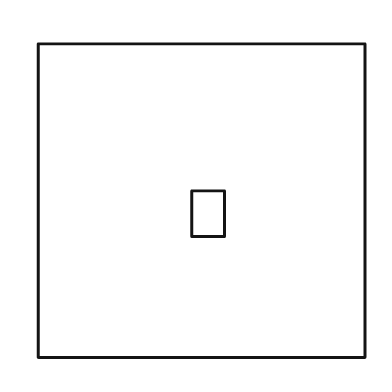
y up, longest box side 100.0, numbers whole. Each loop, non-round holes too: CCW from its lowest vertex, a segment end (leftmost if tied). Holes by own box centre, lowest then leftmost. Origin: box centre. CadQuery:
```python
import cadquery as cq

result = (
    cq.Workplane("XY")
    .moveTo(-50.0, -48.0)
    .lineTo(50.0, -48.0)
    .lineTo(50.0, 48.0)
    .lineTo(-50.0, 48.0)
    .close()
    .moveTo(-3.0, -11.0)
    .lineTo(7.0, -11.0)
    .lineTo(7.0, 3.0)
    .lineTo(-3.0, 3.0)
    .close()
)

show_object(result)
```